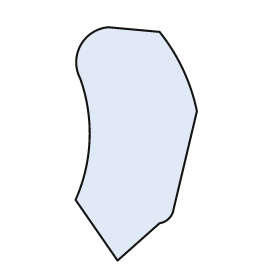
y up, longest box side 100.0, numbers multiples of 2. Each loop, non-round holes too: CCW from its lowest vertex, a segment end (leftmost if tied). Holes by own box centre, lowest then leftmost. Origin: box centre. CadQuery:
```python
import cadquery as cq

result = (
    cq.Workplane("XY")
    .moveTo(-8.0, -50.0)
    .lineTo(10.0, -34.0)
    .threePointArc((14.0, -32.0), (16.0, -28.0))
    .lineTo(26.0, 14.0)
    .threePointArc((20.0, 32.0), (10.0, 48.0))
    .lineTo(-12.0, 50.0)
    .threePointArc((-24.0, 42.0), (-24.0, 28.0))
    .threePointArc((-20.0, 2.0), (-26.0, -24.0))
    .close()
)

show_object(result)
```